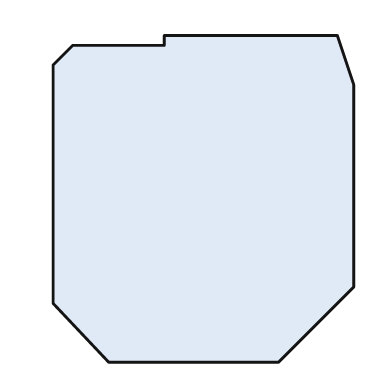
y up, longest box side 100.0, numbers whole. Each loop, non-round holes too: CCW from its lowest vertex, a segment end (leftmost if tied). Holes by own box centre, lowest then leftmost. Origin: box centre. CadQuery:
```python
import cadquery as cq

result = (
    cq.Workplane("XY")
    .moveTo(-29.0, -50.0)
    .lineTo(23.0, -50.0)
    .lineTo(46.0, -27.0)
    .lineTo(46.0, 35.0)
    .lineTo(41.0, 50.0)
    .lineTo(-12.0, 50.0)
    .lineTo(-12.0, 47.0)
    .lineTo(-40.0, 47.0)
    .lineTo(-46.0, 41.0)
    .lineTo(-46.0, -32.0)
    .close()
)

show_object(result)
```